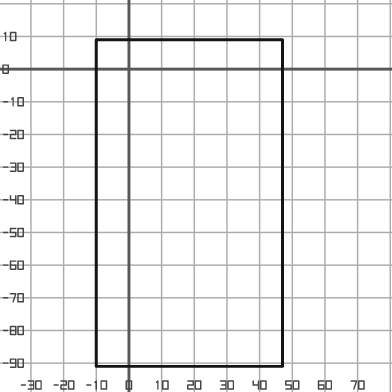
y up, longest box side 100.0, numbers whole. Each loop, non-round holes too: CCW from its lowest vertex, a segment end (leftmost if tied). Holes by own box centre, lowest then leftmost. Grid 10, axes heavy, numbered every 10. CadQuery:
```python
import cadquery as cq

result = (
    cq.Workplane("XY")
    .moveTo(-10.0, -91.0)
    .lineTo(47.0, -91.0)
    .lineTo(47.0, 9.0)
    .lineTo(-10.0, 9.0)
    .close()
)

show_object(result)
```